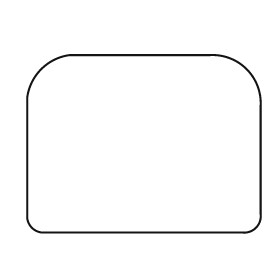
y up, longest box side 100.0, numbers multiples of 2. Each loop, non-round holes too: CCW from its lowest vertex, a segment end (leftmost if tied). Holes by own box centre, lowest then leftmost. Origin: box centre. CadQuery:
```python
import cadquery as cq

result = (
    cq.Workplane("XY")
    .moveTo(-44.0, -38.0)
    .lineTo(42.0, -38.0)
    .threePointArc((48.0, -36.0), (50.0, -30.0))
    .lineTo(50.0, 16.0)
    .threePointArc((44.0, 32.0), (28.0, 38.0))
    .lineTo(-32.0, 38.0)
    .threePointArc((-44.0, 32.0), (-50.0, 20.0))
    .lineTo(-50.0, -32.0)
    .threePointArc((-48.0, -36.0), (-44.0, -38.0))
    .close()
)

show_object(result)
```